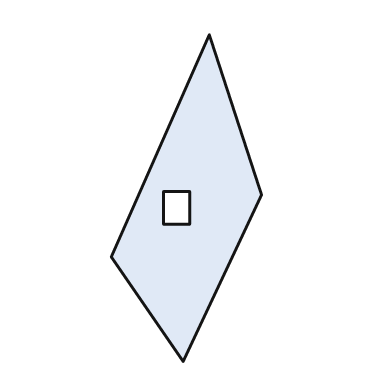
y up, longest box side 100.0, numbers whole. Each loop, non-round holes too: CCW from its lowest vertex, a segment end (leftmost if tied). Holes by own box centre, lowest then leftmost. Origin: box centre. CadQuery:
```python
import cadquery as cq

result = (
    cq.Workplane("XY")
    .moveTo(-1.0, -50.0)
    .lineTo(23.0, 1.0)
    .lineTo(7.0, 50.0)
    .lineTo(-23.0, -18.0)
    .close()
    .moveTo(-7.0, -8.0)
    .lineTo(1.0, -8.0)
    .lineTo(1.0, 2.0)
    .lineTo(-7.0, 2.0)
    .close()
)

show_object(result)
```